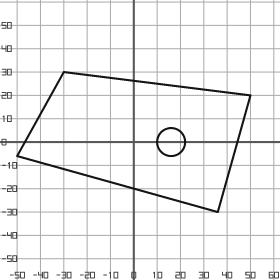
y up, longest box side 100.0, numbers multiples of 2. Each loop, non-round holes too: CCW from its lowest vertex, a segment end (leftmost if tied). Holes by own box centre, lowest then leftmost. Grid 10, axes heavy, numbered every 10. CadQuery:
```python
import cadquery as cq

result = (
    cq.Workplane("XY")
    .moveTo(36.0, -30.0)
    .lineTo(50.0, 20.0)
    .lineTo(-30.0, 30.0)
    .lineTo(-50.0, -6.0)
    .close()
    .moveTo(16.0, 0.0)
    .circle(6.0)
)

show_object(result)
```